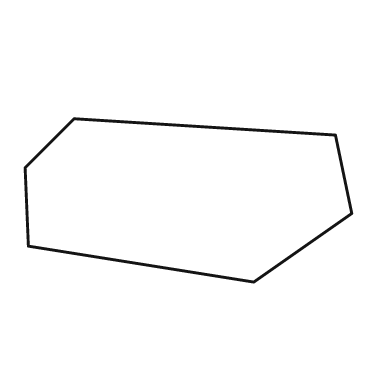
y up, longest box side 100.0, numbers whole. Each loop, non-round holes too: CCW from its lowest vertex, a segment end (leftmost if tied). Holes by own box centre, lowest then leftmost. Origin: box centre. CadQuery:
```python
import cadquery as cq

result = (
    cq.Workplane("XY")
    .moveTo(20.0, -25.0)
    .lineTo(50.0, -4.0)
    .lineTo(45.0, 20.0)
    .lineTo(-35.0, 25.0)
    .lineTo(-50.0, 10.0)
    .lineTo(-49.0, -14.0)
    .close()
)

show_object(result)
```